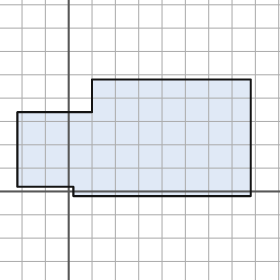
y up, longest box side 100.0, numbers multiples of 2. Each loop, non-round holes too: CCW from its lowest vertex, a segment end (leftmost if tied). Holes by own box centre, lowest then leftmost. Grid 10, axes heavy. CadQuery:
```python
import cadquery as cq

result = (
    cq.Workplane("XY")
    .moveTo(2.0, -2.0)
    .lineTo(78.0, -2.0)
    .lineTo(78.0, 48.0)
    .lineTo(10.0, 48.0)
    .lineTo(10.0, 34.0)
    .lineTo(-22.0, 34.0)
    .lineTo(-22.0, 2.0)
    .lineTo(2.0, 2.0)
    .close()
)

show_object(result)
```